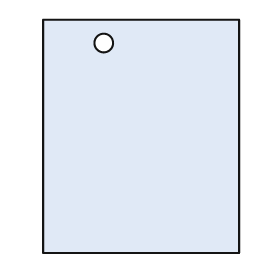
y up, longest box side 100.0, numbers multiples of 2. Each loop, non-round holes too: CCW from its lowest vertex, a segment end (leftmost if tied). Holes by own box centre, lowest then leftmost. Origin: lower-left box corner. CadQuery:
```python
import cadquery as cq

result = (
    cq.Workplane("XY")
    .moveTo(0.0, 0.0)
    .lineTo(84.0, 0.0)
    .lineTo(84.0, 100.0)
    .lineTo(0.0, 100.0)
    .close()
    .moveTo(26.0, 90.0)
    .circle(4.0)
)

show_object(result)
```